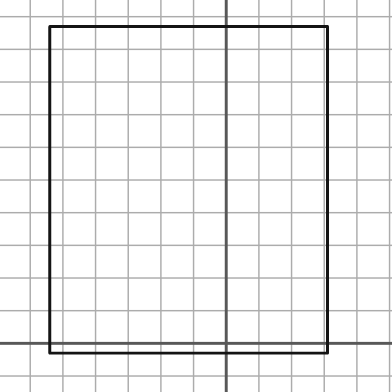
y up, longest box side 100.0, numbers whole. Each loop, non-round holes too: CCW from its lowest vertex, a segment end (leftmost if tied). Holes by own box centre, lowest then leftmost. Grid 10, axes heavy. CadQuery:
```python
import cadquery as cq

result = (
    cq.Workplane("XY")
    .moveTo(-54.0, -3.0)
    .lineTo(31.0, -3.0)
    .lineTo(31.0, 97.0)
    .lineTo(-54.0, 97.0)
    .close()
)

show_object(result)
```